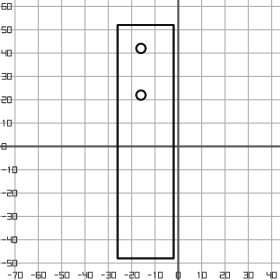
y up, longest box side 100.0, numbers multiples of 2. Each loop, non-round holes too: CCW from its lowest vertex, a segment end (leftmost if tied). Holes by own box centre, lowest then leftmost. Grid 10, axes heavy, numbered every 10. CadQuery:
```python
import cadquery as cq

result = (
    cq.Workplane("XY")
    .moveTo(-26.0, -48.0)
    .lineTo(-2.0, -48.0)
    .lineTo(-2.0, 52.0)
    .lineTo(-26.0, 52.0)
    .close()
    .moveTo(-16.0, 22.0)
    .circle(2.0)
    .moveTo(-16.0, 42.0)
    .circle(2.0)
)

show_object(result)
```